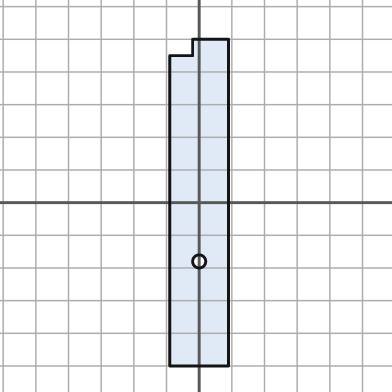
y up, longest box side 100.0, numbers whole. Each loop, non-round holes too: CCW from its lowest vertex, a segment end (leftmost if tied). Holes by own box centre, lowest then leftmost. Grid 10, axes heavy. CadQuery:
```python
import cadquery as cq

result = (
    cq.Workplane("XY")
    .moveTo(-9.0, -50.0)
    .lineTo(9.0, -50.0)
    .lineTo(9.0, 50.0)
    .lineTo(-2.0, 50.0)
    .lineTo(-2.0, 45.0)
    .lineTo(-9.0, 45.0)
    .close()
    .moveTo(0.0, -18.0)
    .circle(2.0)
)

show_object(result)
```